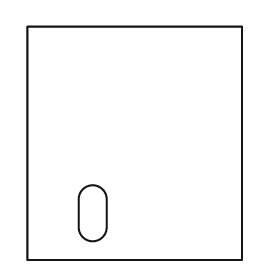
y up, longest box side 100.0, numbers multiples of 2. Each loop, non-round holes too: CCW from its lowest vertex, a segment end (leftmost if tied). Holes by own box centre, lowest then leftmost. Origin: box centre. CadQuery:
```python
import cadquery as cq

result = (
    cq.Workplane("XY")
    .moveTo(-46.0, -50.0)
    .lineTo(46.0, -50.0)
    .lineTo(46.0, 50.0)
    .lineTo(-46.0, 50.0)
    .close()
    .moveTo(-24.0, -36.0)
    .threePointArc((-18.0, -42.0), (-12.0, -36.0))
    .lineTo(-12.0, -24.0)
    .threePointArc((-18.0, -18.0), (-24.0, -24.0))
    .close()
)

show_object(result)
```